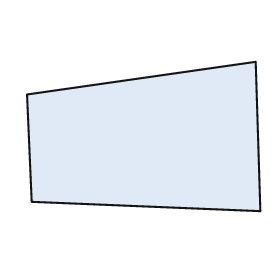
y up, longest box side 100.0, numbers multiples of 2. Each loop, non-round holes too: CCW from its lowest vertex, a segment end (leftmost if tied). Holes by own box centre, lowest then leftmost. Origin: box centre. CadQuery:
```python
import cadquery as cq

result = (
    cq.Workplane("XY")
    .moveTo(50.0, -32.0)
    .lineTo(48.0, 32.0)
    .lineTo(-50.0, 18.0)
    .lineTo(-48.0, -28.0)
    .close()
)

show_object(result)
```